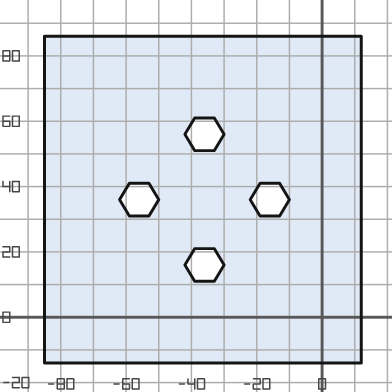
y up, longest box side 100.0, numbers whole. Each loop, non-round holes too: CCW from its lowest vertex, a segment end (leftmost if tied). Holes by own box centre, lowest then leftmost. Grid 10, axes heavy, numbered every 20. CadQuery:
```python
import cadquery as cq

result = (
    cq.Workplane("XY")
    .moveTo(-85.0, -14.0)
    .lineTo(12.0, -14.0)
    .lineTo(12.0, 86.0)
    .lineTo(-85.0, 86.0)
    .close()
    .moveTo(-39.0, 11.0)
    .lineTo(-33.0, 11.0)
    .lineTo(-30.0, 16.0)
    .lineTo(-33.0, 21.0)
    .lineTo(-39.0, 21.0)
    .lineTo(-42.0, 16.0)
    .close()
    .moveTo(-59.0, 31.0)
    .lineTo(-53.0, 31.0)
    .lineTo(-50.0, 36.0)
    .lineTo(-53.0, 41.0)
    .lineTo(-59.0, 41.0)
    .lineTo(-62.0, 36.0)
    .close()
    .moveTo(-19.0, 31.0)
    .lineTo(-13.0, 31.0)
    .lineTo(-10.0, 36.0)
    .lineTo(-13.0, 41.0)
    .lineTo(-19.0, 41.0)
    .lineTo(-22.0, 36.0)
    .close()
    .moveTo(-39.0, 51.0)
    .lineTo(-33.0, 51.0)
    .lineTo(-30.0, 56.0)
    .lineTo(-33.0, 61.0)
    .lineTo(-39.0, 61.0)
    .lineTo(-42.0, 56.0)
    .close()
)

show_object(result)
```